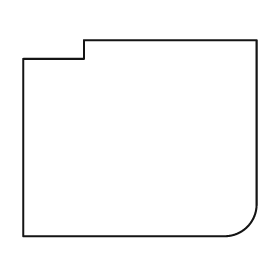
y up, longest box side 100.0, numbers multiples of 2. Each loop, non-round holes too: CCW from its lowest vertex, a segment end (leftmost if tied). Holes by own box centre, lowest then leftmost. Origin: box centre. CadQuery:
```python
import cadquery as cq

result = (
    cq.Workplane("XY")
    .moveTo(-50.0, -42.0)
    .lineTo(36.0, -42.0)
    .threePointArc((46.0, -38.0), (50.0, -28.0))
    .lineTo(50.0, 42.0)
    .lineTo(-24.0, 42.0)
    .lineTo(-24.0, 34.0)
    .lineTo(-50.0, 34.0)
    .close()
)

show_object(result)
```